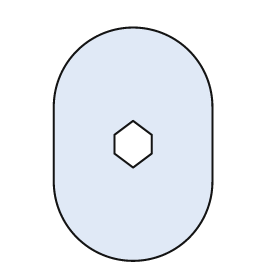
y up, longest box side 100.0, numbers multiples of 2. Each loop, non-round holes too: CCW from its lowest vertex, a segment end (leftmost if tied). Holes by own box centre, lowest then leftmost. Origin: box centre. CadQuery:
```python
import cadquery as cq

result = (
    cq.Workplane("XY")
    .moveTo(-34.0, -16.0)
    .threePointArc((0.0, -50.0), (34.0, -16.0))
    .lineTo(34.0, 16.0)
    .threePointArc((0.0, 50.0), (-34.0, 16.0))
    .close()
    .moveTo(0.0, -10.0)
    .lineTo(8.0, -4.0)
    .lineTo(8.0, 4.0)
    .lineTo(0.0, 10.0)
    .lineTo(-8.0, 4.0)
    .lineTo(-8.0, -4.0)
    .close()
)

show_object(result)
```